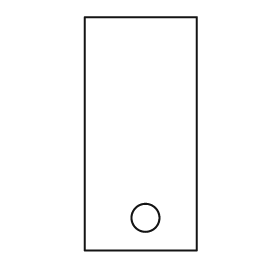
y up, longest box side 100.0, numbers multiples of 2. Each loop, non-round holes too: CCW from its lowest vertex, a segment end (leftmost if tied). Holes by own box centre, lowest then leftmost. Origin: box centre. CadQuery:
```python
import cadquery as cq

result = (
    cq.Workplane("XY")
    .moveTo(-24.0, -50.0)
    .lineTo(24.0, -50.0)
    .lineTo(24.0, 50.0)
    .lineTo(-24.0, 50.0)
    .close()
    .moveTo(2.0, -36.0)
    .circle(6.0)
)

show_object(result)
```